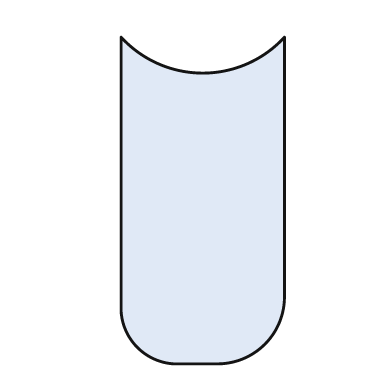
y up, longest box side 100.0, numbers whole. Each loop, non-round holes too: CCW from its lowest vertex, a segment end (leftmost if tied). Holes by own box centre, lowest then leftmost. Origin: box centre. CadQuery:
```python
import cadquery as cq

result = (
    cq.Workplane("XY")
    .moveTo(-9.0, -50.0)
    .lineTo(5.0, -50.0)
    .threePointArc((19.0, -44.0), (25.0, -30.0))
    .lineTo(25.0, 50.0)
    .threePointArc((0.0, 39.0), (-25.0, 50.0))
    .lineTo(-25.0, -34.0)
    .threePointArc((-20.0, -45.0), (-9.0, -50.0))
    .close()
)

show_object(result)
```